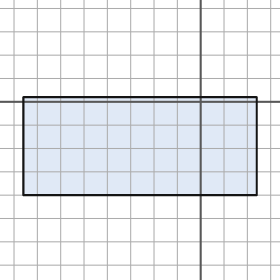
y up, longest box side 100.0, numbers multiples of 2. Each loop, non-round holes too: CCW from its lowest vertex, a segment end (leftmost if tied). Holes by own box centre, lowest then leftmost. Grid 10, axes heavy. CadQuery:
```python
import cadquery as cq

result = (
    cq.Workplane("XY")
    .moveTo(-76.0, -40.0)
    .lineTo(24.0, -40.0)
    .lineTo(24.0, 2.0)
    .lineTo(-76.0, 2.0)
    .close()
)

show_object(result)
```